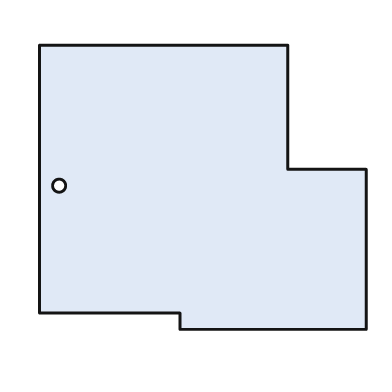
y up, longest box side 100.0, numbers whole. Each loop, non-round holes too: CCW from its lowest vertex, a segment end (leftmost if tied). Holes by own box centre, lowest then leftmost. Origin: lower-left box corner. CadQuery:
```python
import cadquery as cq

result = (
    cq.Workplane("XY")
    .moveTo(43.0, 0.0)
    .lineTo(100.0, 0.0)
    .lineTo(100.0, 49.0)
    .lineTo(76.0, 49.0)
    .lineTo(76.0, 87.0)
    .lineTo(0.0, 87.0)
    .lineTo(0.0, 5.0)
    .lineTo(43.0, 5.0)
    .close()
    .moveTo(6.0, 44.0)
    .circle(2.0)
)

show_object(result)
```